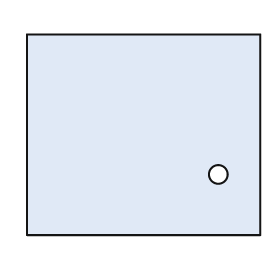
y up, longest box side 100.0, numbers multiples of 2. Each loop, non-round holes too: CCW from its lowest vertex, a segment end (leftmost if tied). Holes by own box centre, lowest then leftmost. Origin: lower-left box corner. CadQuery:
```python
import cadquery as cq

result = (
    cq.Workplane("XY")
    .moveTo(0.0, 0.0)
    .lineTo(100.0, 0.0)
    .lineTo(100.0, 86.0)
    .lineTo(0.0, 86.0)
    .close()
    .moveTo(82.0, 26.0)
    .circle(4.0)
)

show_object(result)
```